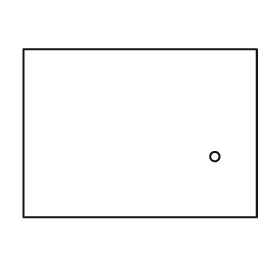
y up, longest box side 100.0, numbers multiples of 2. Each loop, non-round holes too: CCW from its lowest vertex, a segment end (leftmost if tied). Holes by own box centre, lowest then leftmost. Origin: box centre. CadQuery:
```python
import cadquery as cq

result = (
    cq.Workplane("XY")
    .moveTo(-50.0, -36.0)
    .lineTo(50.0, -36.0)
    .lineTo(50.0, 36.0)
    .lineTo(-50.0, 36.0)
    .close()
    .moveTo(32.0, -10.0)
    .circle(2.0)
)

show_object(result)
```